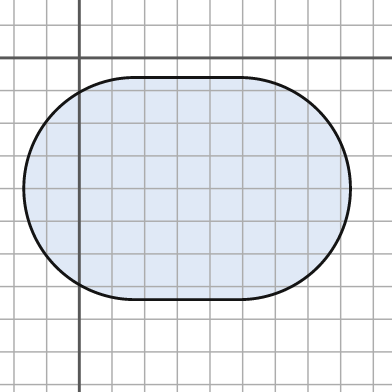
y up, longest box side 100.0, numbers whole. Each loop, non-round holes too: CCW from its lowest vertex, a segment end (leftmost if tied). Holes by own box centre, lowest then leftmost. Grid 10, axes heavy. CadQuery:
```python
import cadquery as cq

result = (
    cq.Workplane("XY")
    .moveTo(17.0, -74.0)
    .lineTo(49.0, -74.0)
    .threePointArc((83.0, -40.0), (49.0, -6.0))
    .lineTo(17.0, -6.0)
    .threePointArc((-17.0, -40.0), (17.0, -74.0))
    .close()
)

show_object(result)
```